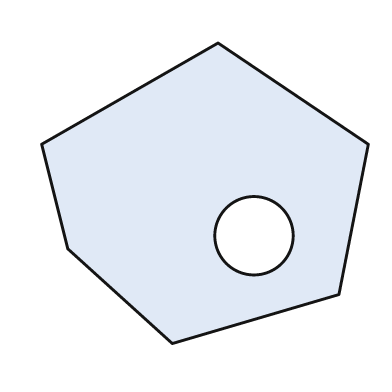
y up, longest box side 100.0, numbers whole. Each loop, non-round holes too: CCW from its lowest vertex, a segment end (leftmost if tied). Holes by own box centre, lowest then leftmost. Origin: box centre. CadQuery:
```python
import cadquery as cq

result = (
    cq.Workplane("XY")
    .moveTo(-10.0, -46.0)
    .lineTo(41.0, -31.0)
    .lineTo(50.0, 15.0)
    .lineTo(4.0, 46.0)
    .lineTo(-50.0, 15.0)
    .lineTo(-42.0, -17.0)
    .close()
    .moveTo(15.0, -13.0)
    .circle(12.0)
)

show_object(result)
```